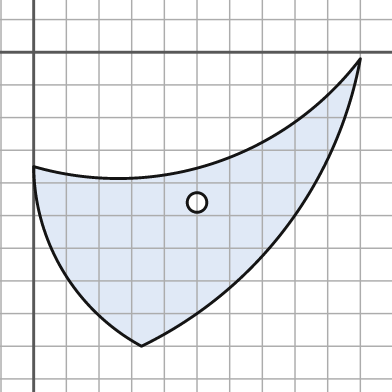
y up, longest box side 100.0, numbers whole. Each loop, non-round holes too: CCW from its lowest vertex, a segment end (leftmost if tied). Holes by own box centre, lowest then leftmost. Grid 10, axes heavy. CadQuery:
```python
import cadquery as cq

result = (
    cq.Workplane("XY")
    .moveTo(33.0, -90.0)
    .threePointArc((77.0, -54.0), (100.0, -2.0))
    .threePointArc((55.0, -34.0), (0.0, -35.0))
    .threePointArc((9.0, -67.0), (33.0, -90.0))
    .close()
    .moveTo(50.0, -46.0)
    .circle(3.0)
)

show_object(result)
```